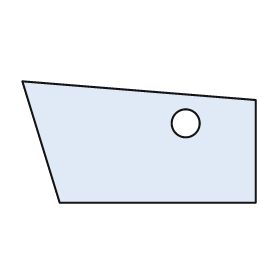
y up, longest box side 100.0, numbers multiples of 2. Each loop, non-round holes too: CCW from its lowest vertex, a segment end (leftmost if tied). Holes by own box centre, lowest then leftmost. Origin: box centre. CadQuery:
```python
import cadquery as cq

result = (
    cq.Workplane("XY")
    .moveTo(-34.0, -26.0)
    .lineTo(50.0, -26.0)
    .lineTo(50.0, 18.0)
    .lineTo(-50.0, 26.0)
    .close()
    .moveTo(20.0, 8.0)
    .circle(6.0)
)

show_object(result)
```